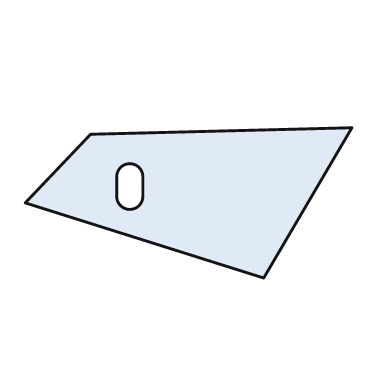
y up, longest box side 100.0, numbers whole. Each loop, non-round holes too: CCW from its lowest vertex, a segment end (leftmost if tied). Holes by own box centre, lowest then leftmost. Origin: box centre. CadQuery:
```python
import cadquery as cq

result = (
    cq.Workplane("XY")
    .moveTo(23.0, -23.0)
    .lineTo(50.0, 23.0)
    .lineTo(-30.0, 21.0)
    .lineTo(-50.0, 0.0)
    .close()
    .moveTo(-22.0, 2.0)
    .threePointArc((-18.0, -2.0), (-14.0, 2.0))
    .lineTo(-14.0, 8.0)
    .threePointArc((-18.0, 12.0), (-22.0, 8.0))
    .close()
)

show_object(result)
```